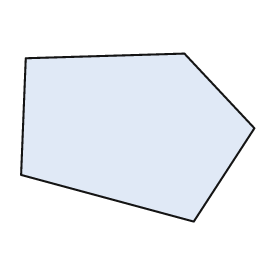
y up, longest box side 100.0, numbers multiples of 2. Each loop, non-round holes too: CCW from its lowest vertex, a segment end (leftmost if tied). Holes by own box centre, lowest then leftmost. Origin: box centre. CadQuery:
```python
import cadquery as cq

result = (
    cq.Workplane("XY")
    .moveTo(24.0, -36.0)
    .lineTo(50.0, 4.0)
    .lineTo(20.0, 36.0)
    .lineTo(-48.0, 34.0)
    .lineTo(-50.0, -16.0)
    .close()
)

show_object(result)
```